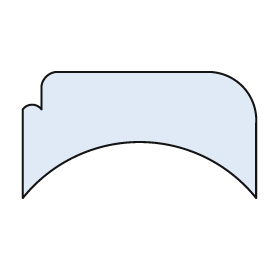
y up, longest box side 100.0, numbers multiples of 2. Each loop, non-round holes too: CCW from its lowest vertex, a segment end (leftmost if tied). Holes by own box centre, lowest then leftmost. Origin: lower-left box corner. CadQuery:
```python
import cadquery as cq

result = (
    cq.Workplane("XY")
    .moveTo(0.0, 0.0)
    .threePointArc((50.0, 24.0), (100.0, 0.0))
    .lineTo(100.0, 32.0)
    .threePointArc((94.0, 48.0), (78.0, 54.0))
    .lineTo(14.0, 54.0)
    .threePointArc((10.0, 52.0), (8.0, 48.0))
    .lineTo(8.0, 38.0)
    .threePointArc((4.0, 40.0), (0.0, 38.0))
    .close()
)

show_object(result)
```